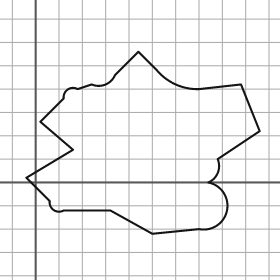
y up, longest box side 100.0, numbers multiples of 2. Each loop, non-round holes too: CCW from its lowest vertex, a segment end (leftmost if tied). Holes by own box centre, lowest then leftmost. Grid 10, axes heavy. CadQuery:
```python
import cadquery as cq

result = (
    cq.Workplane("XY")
    .moveTo(50.0, -22.0)
    .lineTo(70.0, -20.0)
    .threePointArc((82.0, -12.0), (74.0, 0.0))
    .threePointArc((78.0, 4.0), (78.0, 10.0))
    .lineTo(96.0, 22.0)
    .lineTo(88.0, 42.0)
    .lineTo(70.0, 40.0)
    .threePointArc((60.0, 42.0), (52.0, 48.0))
    .lineTo(44.0, 56.0)
    .lineTo(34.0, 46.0)
    .threePointArc((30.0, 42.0), (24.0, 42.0))
    .lineTo(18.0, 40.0)
    .threePointArc((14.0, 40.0), (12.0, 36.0))
    .lineTo(2.0, 26.0)
    .lineTo(16.0, 14.0)
    .lineTo(-4.0, 2.0)
    .lineTo(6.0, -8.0)
    .threePointArc((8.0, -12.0), (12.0, -12.0))
    .lineTo(32.0, -12.0)
    .close()
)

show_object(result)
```